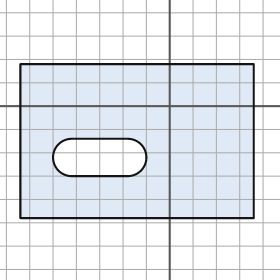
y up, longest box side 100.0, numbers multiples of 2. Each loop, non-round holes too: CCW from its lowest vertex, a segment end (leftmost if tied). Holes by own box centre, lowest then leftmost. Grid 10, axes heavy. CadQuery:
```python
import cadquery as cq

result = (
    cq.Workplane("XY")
    .moveTo(-64.0, -48.0)
    .lineTo(36.0, -48.0)
    .lineTo(36.0, 18.0)
    .lineTo(-64.0, 18.0)
    .close()
    .moveTo(-42.0, -30.0)
    .lineTo(-18.0, -30.0)
    .threePointArc((-10.0, -22.0), (-18.0, -14.0))
    .lineTo(-42.0, -14.0)
    .threePointArc((-50.0, -22.0), (-42.0, -30.0))
    .close()
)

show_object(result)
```